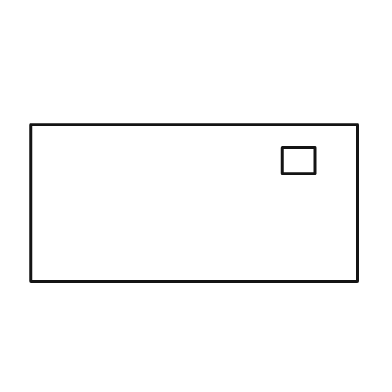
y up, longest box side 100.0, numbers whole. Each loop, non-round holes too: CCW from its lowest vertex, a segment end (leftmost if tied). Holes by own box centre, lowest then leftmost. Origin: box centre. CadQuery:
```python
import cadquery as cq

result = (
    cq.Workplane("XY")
    .moveTo(-50.0, -24.0)
    .lineTo(50.0, -24.0)
    .lineTo(50.0, 24.0)
    .lineTo(-50.0, 24.0)
    .close()
    .moveTo(27.0, 9.0)
    .lineTo(37.0, 9.0)
    .lineTo(37.0, 17.0)
    .lineTo(27.0, 17.0)
    .close()
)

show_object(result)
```